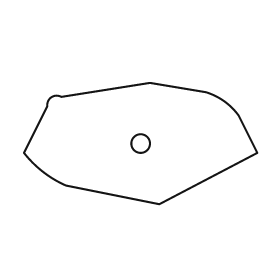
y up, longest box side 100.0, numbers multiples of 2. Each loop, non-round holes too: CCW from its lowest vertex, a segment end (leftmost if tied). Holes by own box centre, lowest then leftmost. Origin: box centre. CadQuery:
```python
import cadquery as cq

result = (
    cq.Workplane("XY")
    .moveTo(8.0, -26.0)
    .lineTo(50.0, -4.0)
    .lineTo(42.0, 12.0)
    .threePointArc((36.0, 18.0), (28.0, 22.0))
    .lineTo(4.0, 26.0)
    .lineTo(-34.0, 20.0)
    .threePointArc((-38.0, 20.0), (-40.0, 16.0))
    .lineTo(-50.0, -4.0)
    .threePointArc((-42.0, -12.0), (-32.0, -18.0))
    .close()
    .moveTo(0.0, 0.0)
    .circle(4.0)
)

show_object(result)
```